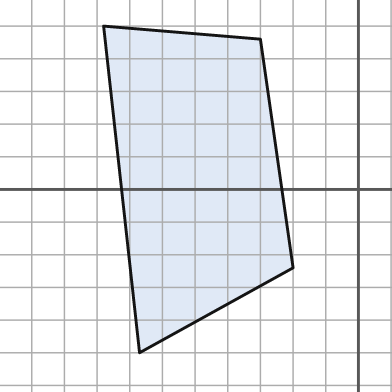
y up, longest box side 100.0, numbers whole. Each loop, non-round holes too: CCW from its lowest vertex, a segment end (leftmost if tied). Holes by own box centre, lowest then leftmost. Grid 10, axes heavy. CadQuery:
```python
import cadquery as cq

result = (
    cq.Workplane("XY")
    .moveTo(-67.0, -50.0)
    .lineTo(-20.0, -24.0)
    .lineTo(-30.0, 46.0)
    .lineTo(-78.0, 50.0)
    .close()
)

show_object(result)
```